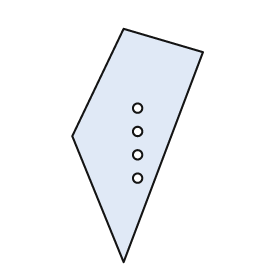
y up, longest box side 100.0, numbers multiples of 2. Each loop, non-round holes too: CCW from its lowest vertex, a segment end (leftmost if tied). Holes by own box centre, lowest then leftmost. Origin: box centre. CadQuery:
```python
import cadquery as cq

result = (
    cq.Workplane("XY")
    .moveTo(-6.0, -50.0)
    .lineTo(28.0, 40.0)
    .lineTo(-6.0, 50.0)
    .lineTo(-28.0, 4.0)
    .close()
    .moveTo(0.0, -14.0)
    .circle(2.0)
    .moveTo(0.0, -4.0)
    .circle(2.0)
    .moveTo(0.0, 6.0)
    .circle(2.0)
    .moveTo(0.0, 16.0)
    .circle(2.0)
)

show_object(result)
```